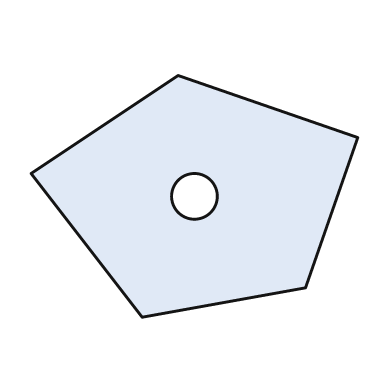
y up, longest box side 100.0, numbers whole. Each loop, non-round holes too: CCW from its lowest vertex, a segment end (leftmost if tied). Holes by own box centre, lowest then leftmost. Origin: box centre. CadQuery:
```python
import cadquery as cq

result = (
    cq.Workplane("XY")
    .moveTo(-16.0, -37.0)
    .lineTo(34.0, -28.0)
    .lineTo(50.0, 18.0)
    .lineTo(-5.0, 37.0)
    .lineTo(-50.0, 7.0)
    .close()
    .moveTo(0.0, 0.0)
    .circle(7.0)
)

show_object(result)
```